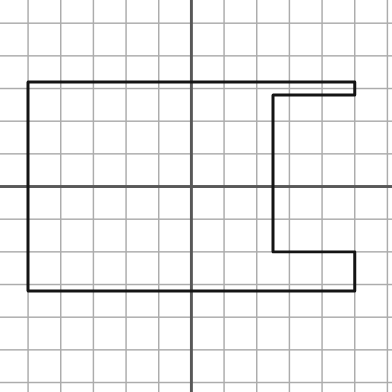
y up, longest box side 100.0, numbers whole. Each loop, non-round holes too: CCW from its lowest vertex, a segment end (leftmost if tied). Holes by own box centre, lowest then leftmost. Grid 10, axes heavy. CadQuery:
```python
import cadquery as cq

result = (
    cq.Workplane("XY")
    .moveTo(-50.0, -32.0)
    .lineTo(50.0, -32.0)
    .lineTo(50.0, -20.0)
    .lineTo(25.0, -20.0)
    .lineTo(25.0, 28.0)
    .lineTo(50.0, 28.0)
    .lineTo(50.0, 32.0)
    .lineTo(-50.0, 32.0)
    .close()
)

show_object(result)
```